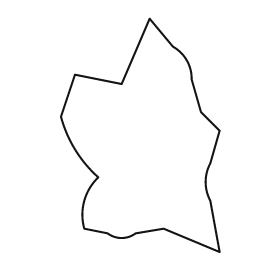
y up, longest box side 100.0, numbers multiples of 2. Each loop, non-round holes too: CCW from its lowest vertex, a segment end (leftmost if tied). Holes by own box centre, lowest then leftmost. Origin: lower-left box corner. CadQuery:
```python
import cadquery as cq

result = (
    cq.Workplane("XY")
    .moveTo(68.0, 0.0)
    .lineTo(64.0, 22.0)
    .threePointArc((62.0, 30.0), (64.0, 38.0))
    .lineTo(68.0, 52.0)
    .lineTo(60.0, 60.0)
    .lineTo(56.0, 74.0)
    .threePointArc((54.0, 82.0), (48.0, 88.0))
    .lineTo(38.0, 100.0)
    .lineTo(26.0, 72.0)
    .lineTo(6.0, 76.0)
    .lineTo(0.0, 58.0)
    .threePointArc((6.0, 44.0), (16.0, 32.0))
    .threePointArc((10.0, 22.0), (10.0, 10.0))
    .lineTo(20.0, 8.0)
    .threePointArc((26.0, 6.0), (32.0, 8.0))
    .lineTo(44.0, 10.0)
    .close()
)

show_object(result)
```